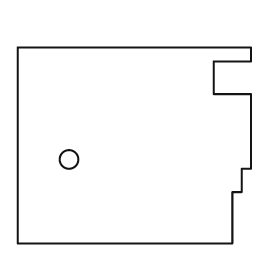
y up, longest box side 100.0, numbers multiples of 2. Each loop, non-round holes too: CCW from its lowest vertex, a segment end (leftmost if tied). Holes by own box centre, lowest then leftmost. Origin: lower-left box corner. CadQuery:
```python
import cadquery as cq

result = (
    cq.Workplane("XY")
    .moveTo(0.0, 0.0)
    .lineTo(92.0, 0.0)
    .lineTo(92.0, 22.0)
    .lineTo(96.0, 22.0)
    .lineTo(96.0, 32.0)
    .lineTo(100.0, 32.0)
    .lineTo(100.0, 64.0)
    .lineTo(84.0, 64.0)
    .lineTo(84.0, 78.0)
    .lineTo(100.0, 78.0)
    .lineTo(100.0, 84.0)
    .lineTo(0.0, 84.0)
    .close()
    .moveTo(22.0, 36.0)
    .circle(4.0)
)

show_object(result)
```